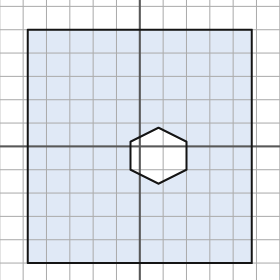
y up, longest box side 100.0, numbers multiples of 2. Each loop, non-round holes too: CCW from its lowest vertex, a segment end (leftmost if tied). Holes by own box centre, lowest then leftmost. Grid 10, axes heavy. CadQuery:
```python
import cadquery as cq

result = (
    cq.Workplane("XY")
    .moveTo(-48.0, -50.0)
    .lineTo(48.0, -50.0)
    .lineTo(48.0, 50.0)
    .lineTo(-48.0, 50.0)
    .close()
    .moveTo(8.0, -16.0)
    .lineTo(20.0, -10.0)
    .lineTo(20.0, 2.0)
    .lineTo(8.0, 8.0)
    .lineTo(-4.0, 2.0)
    .lineTo(-4.0, -10.0)
    .close()
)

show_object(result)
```